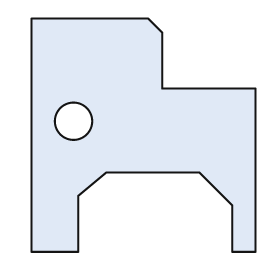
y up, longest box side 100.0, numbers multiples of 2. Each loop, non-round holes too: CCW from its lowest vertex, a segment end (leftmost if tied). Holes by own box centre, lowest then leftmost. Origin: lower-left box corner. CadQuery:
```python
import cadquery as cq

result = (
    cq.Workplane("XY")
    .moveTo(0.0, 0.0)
    .lineTo(20.0, 0.0)
    .lineTo(20.0, 24.0)
    .lineTo(32.0, 34.0)
    .lineTo(72.0, 34.0)
    .lineTo(86.0, 20.0)
    .lineTo(86.0, 0.0)
    .lineTo(96.0, 0.0)
    .lineTo(96.0, 70.0)
    .lineTo(56.0, 70.0)
    .lineTo(56.0, 94.0)
    .lineTo(50.0, 100.0)
    .lineTo(0.0, 100.0)
    .close()
    .moveTo(18.0, 56.0)
    .circle(8.0)
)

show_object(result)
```